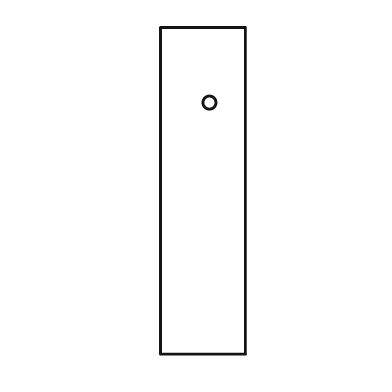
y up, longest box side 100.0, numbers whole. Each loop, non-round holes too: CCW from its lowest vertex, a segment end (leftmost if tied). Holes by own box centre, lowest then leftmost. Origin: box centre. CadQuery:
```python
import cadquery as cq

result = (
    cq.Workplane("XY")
    .moveTo(-13.0, -50.0)
    .lineTo(13.0, -50.0)
    .lineTo(13.0, 50.0)
    .lineTo(-13.0, 50.0)
    .close()
    .moveTo(2.0, 27.0)
    .circle(2.0)
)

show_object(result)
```